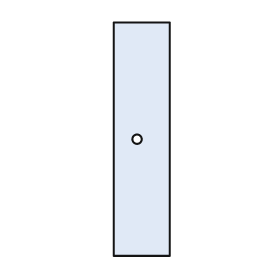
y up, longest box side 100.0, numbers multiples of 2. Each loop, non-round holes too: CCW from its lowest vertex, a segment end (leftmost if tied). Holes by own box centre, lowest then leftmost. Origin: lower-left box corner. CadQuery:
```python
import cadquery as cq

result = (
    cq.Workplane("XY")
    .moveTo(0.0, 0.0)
    .lineTo(24.0, 0.0)
    .lineTo(24.0, 100.0)
    .lineTo(0.0, 100.0)
    .close()
    .moveTo(10.0, 50.0)
    .circle(2.0)
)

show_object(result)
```